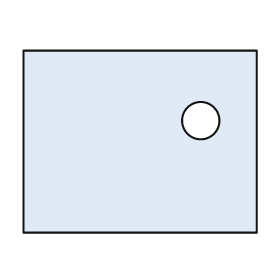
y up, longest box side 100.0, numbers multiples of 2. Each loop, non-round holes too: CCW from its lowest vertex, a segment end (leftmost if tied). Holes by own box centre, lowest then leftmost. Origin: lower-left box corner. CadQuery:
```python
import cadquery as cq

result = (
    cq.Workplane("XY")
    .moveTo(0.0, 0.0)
    .lineTo(100.0, 0.0)
    .lineTo(100.0, 78.0)
    .lineTo(0.0, 78.0)
    .close()
    .moveTo(76.0, 48.0)
    .circle(8.0)
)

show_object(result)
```